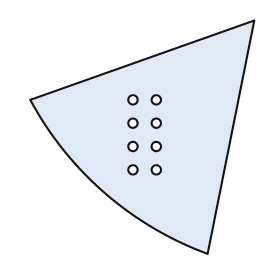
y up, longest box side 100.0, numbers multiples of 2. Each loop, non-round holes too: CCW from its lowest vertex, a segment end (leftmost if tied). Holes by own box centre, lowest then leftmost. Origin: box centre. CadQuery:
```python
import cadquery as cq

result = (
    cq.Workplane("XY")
    .moveTo(28.0, -50.0)
    .lineTo(48.0, 50.0)
    .lineTo(-48.0, 16.0)
    .threePointArc((-16.0, -24.0), (28.0, -50.0))
    .close()
    .moveTo(-4.0, -14.0)
    .circle(2.0)
    .moveTo(6.0, -14.0)
    .circle(2.0)
    .moveTo(-4.0, -4.0)
    .circle(2.0)
    .moveTo(6.0, -4.0)
    .circle(2.0)
    .moveTo(-4.0, 6.0)
    .circle(2.0)
    .moveTo(6.0, 6.0)
    .circle(2.0)
    .moveTo(-4.0, 16.0)
    .circle(2.0)
    .moveTo(6.0, 16.0)
    .circle(2.0)
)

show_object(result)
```